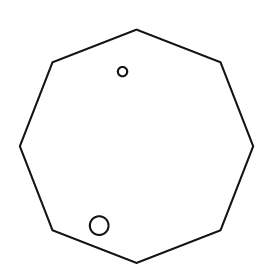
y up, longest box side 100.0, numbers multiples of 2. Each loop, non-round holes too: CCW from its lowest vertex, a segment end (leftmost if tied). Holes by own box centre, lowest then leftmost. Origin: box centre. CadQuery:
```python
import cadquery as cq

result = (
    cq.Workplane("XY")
    .moveTo(0.0, -50.0)
    .lineTo(36.0, -36.0)
    .lineTo(50.0, 0.0)
    .lineTo(36.0, 36.0)
    .lineTo(0.0, 50.0)
    .lineTo(-36.0, 36.0)
    .lineTo(-50.0, 0.0)
    .lineTo(-36.0, -36.0)
    .close()
    .moveTo(-16.0, -34.0)
    .circle(4.0)
    .moveTo(-6.0, 32.0)
    .circle(2.0)
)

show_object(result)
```